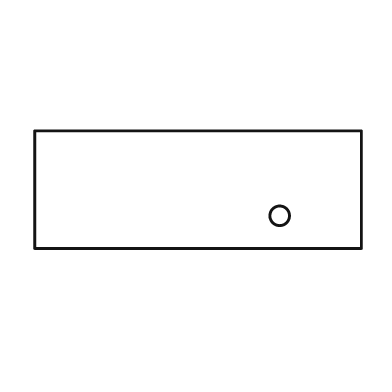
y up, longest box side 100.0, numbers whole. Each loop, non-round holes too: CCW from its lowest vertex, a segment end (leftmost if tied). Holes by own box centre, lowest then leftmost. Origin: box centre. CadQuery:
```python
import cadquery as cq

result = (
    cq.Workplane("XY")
    .moveTo(-50.0, -18.0)
    .lineTo(50.0, -18.0)
    .lineTo(50.0, 18.0)
    .lineTo(-50.0, 18.0)
    .close()
    .moveTo(25.0, -8.0)
    .circle(3.0)
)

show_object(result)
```